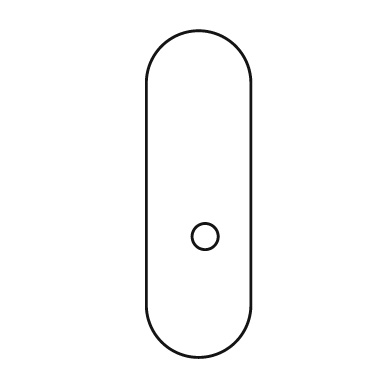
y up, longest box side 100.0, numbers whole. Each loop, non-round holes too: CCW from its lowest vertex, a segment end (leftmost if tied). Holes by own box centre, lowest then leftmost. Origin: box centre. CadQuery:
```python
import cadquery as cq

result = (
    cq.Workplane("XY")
    .moveTo(-16.0, -34.0)
    .threePointArc((0.0, -50.0), (16.0, -34.0))
    .lineTo(16.0, 34.0)
    .threePointArc((0.0, 50.0), (-16.0, 34.0))
    .close()
    .moveTo(2.0, -13.0)
    .circle(4.0)
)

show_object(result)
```